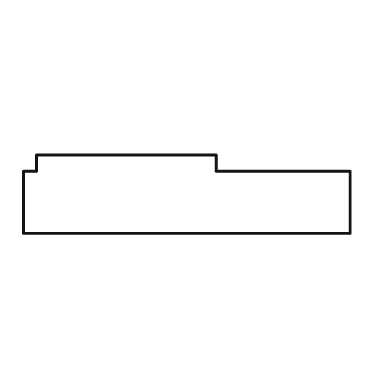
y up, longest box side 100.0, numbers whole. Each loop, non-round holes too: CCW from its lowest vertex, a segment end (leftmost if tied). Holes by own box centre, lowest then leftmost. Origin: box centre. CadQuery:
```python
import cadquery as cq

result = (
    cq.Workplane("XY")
    .moveTo(-50.0, -12.0)
    .lineTo(50.0, -12.0)
    .lineTo(50.0, 7.0)
    .lineTo(9.0, 7.0)
    .lineTo(9.0, 12.0)
    .lineTo(-46.0, 12.0)
    .lineTo(-46.0, 7.0)
    .lineTo(-50.0, 7.0)
    .close()
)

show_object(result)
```